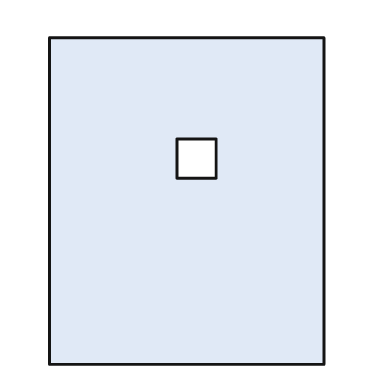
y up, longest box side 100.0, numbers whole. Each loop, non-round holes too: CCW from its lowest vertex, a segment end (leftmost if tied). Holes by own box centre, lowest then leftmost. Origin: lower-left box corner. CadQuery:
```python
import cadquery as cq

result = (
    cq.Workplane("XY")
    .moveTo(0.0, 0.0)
    .lineTo(84.0, 0.0)
    .lineTo(84.0, 100.0)
    .lineTo(0.0, 100.0)
    .close()
    .moveTo(39.0, 57.0)
    .lineTo(51.0, 57.0)
    .lineTo(51.0, 69.0)
    .lineTo(39.0, 69.0)
    .close()
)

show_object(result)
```